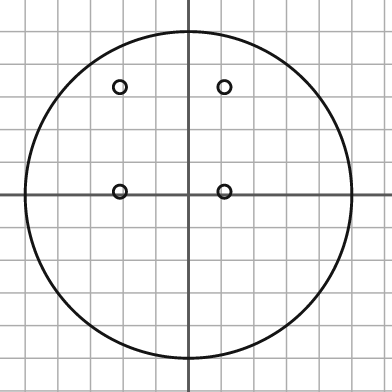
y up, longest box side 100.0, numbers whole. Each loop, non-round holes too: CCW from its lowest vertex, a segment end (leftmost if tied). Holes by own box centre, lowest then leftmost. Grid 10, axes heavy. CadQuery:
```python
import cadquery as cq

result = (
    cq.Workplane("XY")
    .moveTo(0.0, 0.0)
    .circle(50.0)
    .moveTo(-21.0, 1.0)
    .circle(2.0)
    .moveTo(11.0, 1.0)
    .circle(2.0)
    .moveTo(-21.0, 33.0)
    .circle(2.0)
    .moveTo(11.0, 33.0)
    .circle(2.0)
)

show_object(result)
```